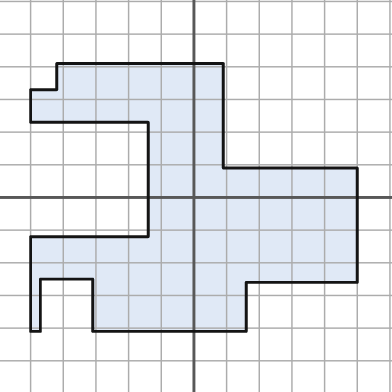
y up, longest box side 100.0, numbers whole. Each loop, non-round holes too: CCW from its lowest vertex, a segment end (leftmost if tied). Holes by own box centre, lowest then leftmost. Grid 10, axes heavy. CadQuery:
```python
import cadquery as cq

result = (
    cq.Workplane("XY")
    .moveTo(-50.0, -41.0)
    .lineTo(-47.0, -41.0)
    .lineTo(-47.0, -25.0)
    .lineTo(-31.0, -25.0)
    .lineTo(-31.0, -41.0)
    .lineTo(16.0, -41.0)
    .lineTo(16.0, -26.0)
    .lineTo(50.0, -26.0)
    .lineTo(50.0, 9.0)
    .lineTo(9.0, 9.0)
    .lineTo(9.0, 41.0)
    .lineTo(-42.0, 41.0)
    .lineTo(-42.0, 33.0)
    .lineTo(-50.0, 33.0)
    .lineTo(-50.0, 23.0)
    .lineTo(-14.0, 23.0)
    .lineTo(-14.0, -12.0)
    .lineTo(-50.0, -12.0)
    .close()
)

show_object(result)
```